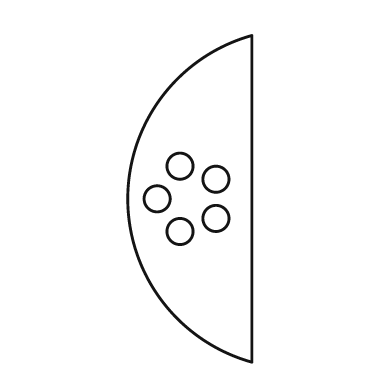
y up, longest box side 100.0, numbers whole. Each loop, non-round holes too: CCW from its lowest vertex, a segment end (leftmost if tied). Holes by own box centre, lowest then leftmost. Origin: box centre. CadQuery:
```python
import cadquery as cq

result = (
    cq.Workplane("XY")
    .moveTo(19.0, -50.0)
    .lineTo(19.0, 50.0)
    .threePointArc((-19.0, 0.0), (19.0, -50.0))
    .close()
    .moveTo(-3.0, -10.0)
    .circle(4.0)
    .moveTo(8.0, -6.0)
    .circle(4.0)
    .moveTo(-10.0, 0.0)
    .circle(4.0)
    .moveTo(8.0, 6.0)
    .circle(4.0)
    .moveTo(-3.0, 10.0)
    .circle(4.0)
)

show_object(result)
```